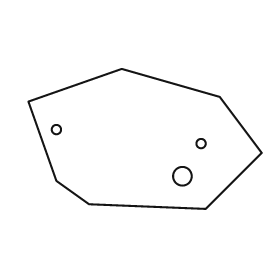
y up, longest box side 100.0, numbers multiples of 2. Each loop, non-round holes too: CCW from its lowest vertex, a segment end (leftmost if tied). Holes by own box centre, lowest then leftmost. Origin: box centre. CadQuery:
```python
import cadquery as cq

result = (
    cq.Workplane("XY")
    .moveTo(26.0, -30.0)
    .lineTo(50.0, -6.0)
    .lineTo(32.0, 18.0)
    .lineTo(-10.0, 30.0)
    .lineTo(-50.0, 16.0)
    .lineTo(-38.0, -18.0)
    .lineTo(-24.0, -28.0)
    .close()
    .moveTo(16.0, -16.0)
    .circle(4.0)
    .moveTo(24.0, -2.0)
    .circle(2.0)
    .moveTo(-38.0, 4.0)
    .circle(2.0)
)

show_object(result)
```